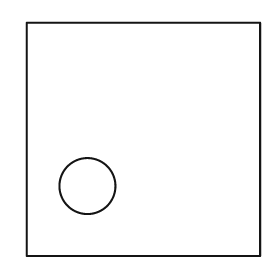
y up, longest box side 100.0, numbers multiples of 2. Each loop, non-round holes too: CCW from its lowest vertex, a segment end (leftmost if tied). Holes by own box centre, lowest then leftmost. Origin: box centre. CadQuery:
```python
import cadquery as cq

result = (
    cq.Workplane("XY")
    .moveTo(-50.0, -50.0)
    .lineTo(50.0, -50.0)
    .lineTo(50.0, 50.0)
    .lineTo(-50.0, 50.0)
    .close()
    .moveTo(-24.0, -20.0)
    .circle(12.0)
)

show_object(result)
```